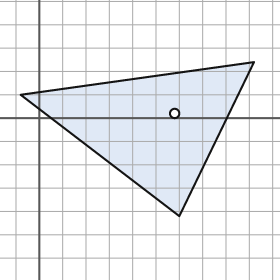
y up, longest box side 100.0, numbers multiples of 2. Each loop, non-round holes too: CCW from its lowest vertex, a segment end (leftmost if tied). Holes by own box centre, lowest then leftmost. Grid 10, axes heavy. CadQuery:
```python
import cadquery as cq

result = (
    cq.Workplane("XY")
    .moveTo(60.0, -42.0)
    .lineTo(92.0, 24.0)
    .lineTo(-8.0, 10.0)
    .close()
    .moveTo(58.0, 2.0)
    .circle(2.0)
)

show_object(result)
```